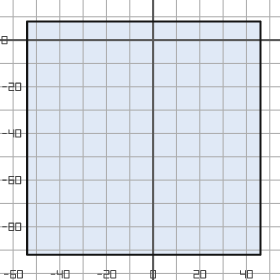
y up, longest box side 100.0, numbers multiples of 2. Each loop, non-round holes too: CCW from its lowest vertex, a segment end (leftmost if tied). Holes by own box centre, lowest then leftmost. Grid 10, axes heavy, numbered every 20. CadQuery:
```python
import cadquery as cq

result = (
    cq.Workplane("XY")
    .moveTo(-54.0, -92.0)
    .lineTo(46.0, -92.0)
    .lineTo(46.0, 8.0)
    .lineTo(-54.0, 8.0)
    .close()
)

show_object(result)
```